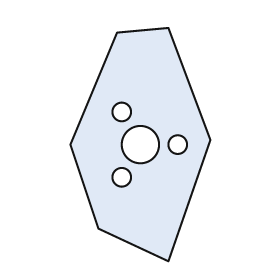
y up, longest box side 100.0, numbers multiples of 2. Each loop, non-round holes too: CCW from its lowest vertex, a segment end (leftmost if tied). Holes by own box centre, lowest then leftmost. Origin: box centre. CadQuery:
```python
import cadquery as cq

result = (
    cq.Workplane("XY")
    .moveTo(12.0, -50.0)
    .lineTo(30.0, 2.0)
    .lineTo(12.0, 50.0)
    .lineTo(-10.0, 48.0)
    .lineTo(-30.0, 0.0)
    .lineTo(-18.0, -36.0)
    .close()
    .moveTo(-8.0, -14.0)
    .circle(4.0)
    .moveTo(0.0, 0.0)
    .circle(8.0)
    .moveTo(16.0, 0.0)
    .circle(4.0)
    .moveTo(-8.0, 14.0)
    .circle(4.0)
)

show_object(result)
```